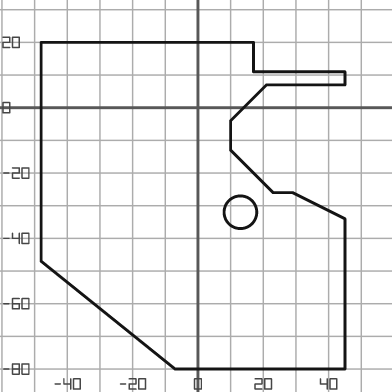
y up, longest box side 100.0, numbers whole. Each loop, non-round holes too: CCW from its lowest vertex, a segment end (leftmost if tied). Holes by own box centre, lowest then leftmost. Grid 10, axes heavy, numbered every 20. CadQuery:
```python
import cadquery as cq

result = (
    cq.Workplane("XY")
    .moveTo(-7.0, -80.0)
    .lineTo(45.0, -80.0)
    .lineTo(45.0, -34.0)
    .lineTo(29.0, -26.0)
    .lineTo(23.0, -26.0)
    .lineTo(10.0, -13.0)
    .lineTo(10.0, -4.0)
    .lineTo(21.0, 7.0)
    .lineTo(45.0, 7.0)
    .lineTo(45.0, 11.0)
    .lineTo(17.0, 11.0)
    .lineTo(17.0, 20.0)
    .lineTo(-48.0, 20.0)
    .lineTo(-48.0, -47.0)
    .close()
    .moveTo(13.0, -32.0)
    .circle(5.0)
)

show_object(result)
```